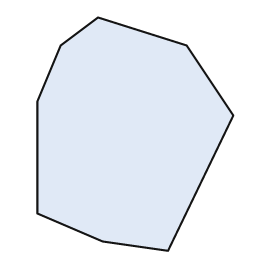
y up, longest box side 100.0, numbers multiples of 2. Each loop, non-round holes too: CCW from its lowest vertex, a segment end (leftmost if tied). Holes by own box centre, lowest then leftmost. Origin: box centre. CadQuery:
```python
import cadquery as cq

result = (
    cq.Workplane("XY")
    .moveTo(14.0, -50.0)
    .lineTo(42.0, 8.0)
    .lineTo(22.0, 38.0)
    .lineTo(-16.0, 50.0)
    .lineTo(-32.0, 38.0)
    .lineTo(-42.0, 14.0)
    .lineTo(-42.0, -34.0)
    .lineTo(-14.0, -46.0)
    .close()
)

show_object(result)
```